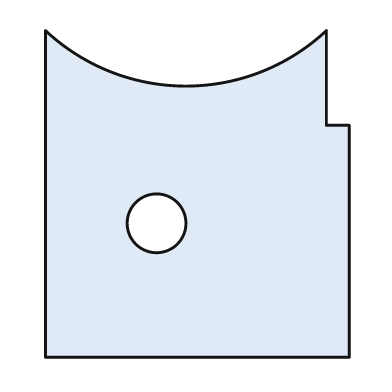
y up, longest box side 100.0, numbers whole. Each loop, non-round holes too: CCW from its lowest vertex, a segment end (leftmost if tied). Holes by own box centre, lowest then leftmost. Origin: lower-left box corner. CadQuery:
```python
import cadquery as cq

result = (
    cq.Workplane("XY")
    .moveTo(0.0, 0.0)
    .lineTo(93.0, 0.0)
    .lineTo(93.0, 71.0)
    .lineTo(86.0, 71.0)
    .lineTo(86.0, 100.0)
    .threePointArc((43.0, 83.0), (0.0, 100.0))
    .close()
    .moveTo(34.0, 41.0)
    .circle(9.0)
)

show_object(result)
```